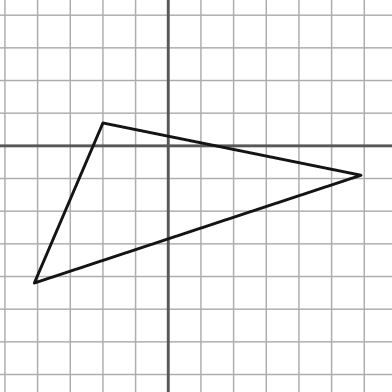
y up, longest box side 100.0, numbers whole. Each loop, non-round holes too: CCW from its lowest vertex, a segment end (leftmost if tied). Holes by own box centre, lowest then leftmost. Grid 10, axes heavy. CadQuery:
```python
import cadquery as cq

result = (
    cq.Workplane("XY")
    .moveTo(-41.0, -42.0)
    .lineTo(59.0, -9.0)
    .lineTo(-20.0, 7.0)
    .close()
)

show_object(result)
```